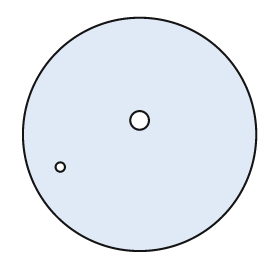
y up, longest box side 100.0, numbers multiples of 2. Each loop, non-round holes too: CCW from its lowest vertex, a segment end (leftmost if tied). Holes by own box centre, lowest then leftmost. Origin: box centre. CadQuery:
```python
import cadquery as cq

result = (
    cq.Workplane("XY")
    .moveTo(0.0, 0.0)
    .circle(50.0)
    .moveTo(-34.0, -14.0)
    .circle(2.0)
    .moveTo(0.0, 6.0)
    .circle(4.0)
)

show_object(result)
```